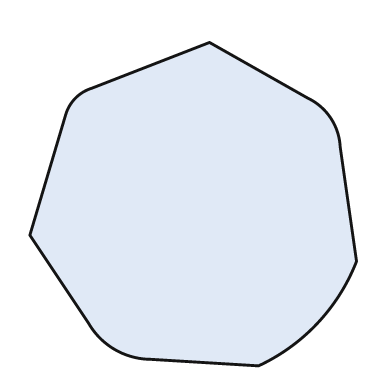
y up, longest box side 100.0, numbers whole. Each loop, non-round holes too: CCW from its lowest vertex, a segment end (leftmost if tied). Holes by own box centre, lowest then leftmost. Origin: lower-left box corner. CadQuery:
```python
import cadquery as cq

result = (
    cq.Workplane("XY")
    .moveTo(70.0, 0.0)
    .threePointArc((88.0, 13.0), (100.0, 32.0))
    .lineTo(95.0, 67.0)
    .threePointArc((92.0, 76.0), (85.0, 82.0))
    .lineTo(55.0, 99.0)
    .lineTo(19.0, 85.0)
    .threePointArc((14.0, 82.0), (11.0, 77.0))
    .lineTo(0.0, 40.0)
    .lineTo(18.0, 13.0)
    .threePointArc((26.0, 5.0), (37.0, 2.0))
    .close()
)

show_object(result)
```